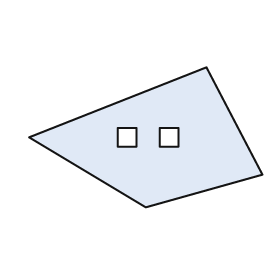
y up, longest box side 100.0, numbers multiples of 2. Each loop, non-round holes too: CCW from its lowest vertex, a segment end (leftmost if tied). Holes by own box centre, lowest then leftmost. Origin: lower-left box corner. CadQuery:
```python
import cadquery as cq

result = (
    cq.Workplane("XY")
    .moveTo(50.0, 0.0)
    .lineTo(100.0, 14.0)
    .lineTo(76.0, 60.0)
    .lineTo(0.0, 30.0)
    .close()
    .moveTo(38.0, 26.0)
    .lineTo(46.0, 26.0)
    .lineTo(46.0, 34.0)
    .lineTo(38.0, 34.0)
    .close()
    .moveTo(56.0, 26.0)
    .lineTo(64.0, 26.0)
    .lineTo(64.0, 34.0)
    .lineTo(56.0, 34.0)
    .close()
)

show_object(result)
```